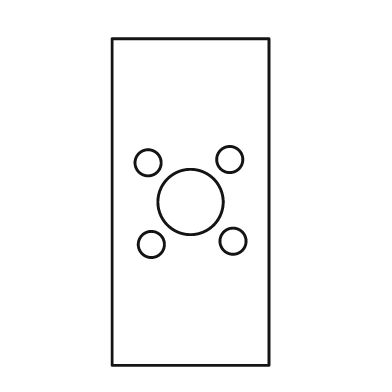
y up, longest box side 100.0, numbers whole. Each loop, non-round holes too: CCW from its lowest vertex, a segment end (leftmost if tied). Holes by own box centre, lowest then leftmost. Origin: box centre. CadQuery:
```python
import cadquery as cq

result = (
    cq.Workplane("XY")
    .moveTo(-24.0, -50.0)
    .lineTo(24.0, -50.0)
    .lineTo(24.0, 50.0)
    .lineTo(-24.0, 50.0)
    .close()
    .moveTo(-12.0, -13.0)
    .circle(4.0)
    .moveTo(13.0, -12.0)
    .circle(4.0)
    .moveTo(0.0, 0.0)
    .circle(10.0)
    .moveTo(-13.0, 12.0)
    .circle(4.0)
    .moveTo(12.0, 13.0)
    .circle(4.0)
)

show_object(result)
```